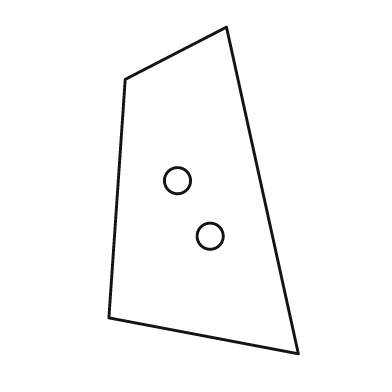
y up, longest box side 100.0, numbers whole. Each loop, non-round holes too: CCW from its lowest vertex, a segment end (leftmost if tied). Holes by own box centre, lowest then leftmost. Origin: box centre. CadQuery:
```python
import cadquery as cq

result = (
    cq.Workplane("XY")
    .moveTo(29.0, -50.0)
    .lineTo(7.0, 50.0)
    .lineTo(-24.0, 34.0)
    .lineTo(-29.0, -39.0)
    .close()
    .moveTo(2.0, -14.0)
    .circle(4.0)
    .moveTo(-8.0, 3.0)
    .circle(4.0)
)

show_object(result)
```